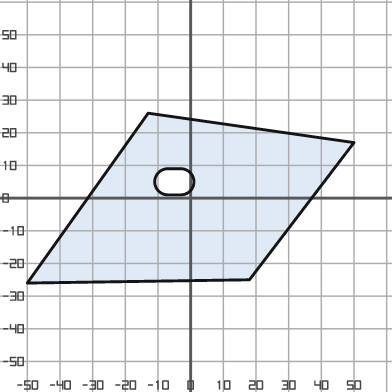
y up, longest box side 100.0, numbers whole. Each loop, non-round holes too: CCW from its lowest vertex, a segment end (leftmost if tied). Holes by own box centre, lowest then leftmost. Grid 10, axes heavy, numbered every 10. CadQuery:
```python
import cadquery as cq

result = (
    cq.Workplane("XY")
    .moveTo(-50.0, -26.0)
    .lineTo(18.0, -25.0)
    .lineTo(50.0, 17.0)
    .lineTo(-13.0, 26.0)
    .close()
    .moveTo(-7.0, 1.0)
    .lineTo(-3.0, 1.0)
    .threePointArc((1.0, 5.0), (-3.0, 9.0))
    .lineTo(-7.0, 9.0)
    .threePointArc((-11.0, 5.0), (-7.0, 1.0))
    .close()
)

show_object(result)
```